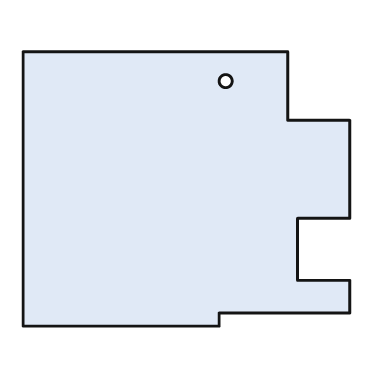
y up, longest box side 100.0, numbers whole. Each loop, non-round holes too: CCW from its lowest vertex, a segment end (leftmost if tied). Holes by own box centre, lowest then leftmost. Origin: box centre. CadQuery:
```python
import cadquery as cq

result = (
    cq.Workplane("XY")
    .moveTo(-50.0, -42.0)
    .lineTo(10.0, -42.0)
    .lineTo(10.0, -38.0)
    .lineTo(50.0, -38.0)
    .lineTo(50.0, -28.0)
    .lineTo(34.0, -28.0)
    .lineTo(34.0, -9.0)
    .lineTo(50.0, -9.0)
    .lineTo(50.0, 21.0)
    .lineTo(31.0, 21.0)
    .lineTo(31.0, 42.0)
    .lineTo(-50.0, 42.0)
    .close()
    .moveTo(12.0, 33.0)
    .circle(2.0)
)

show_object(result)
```